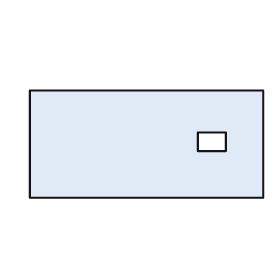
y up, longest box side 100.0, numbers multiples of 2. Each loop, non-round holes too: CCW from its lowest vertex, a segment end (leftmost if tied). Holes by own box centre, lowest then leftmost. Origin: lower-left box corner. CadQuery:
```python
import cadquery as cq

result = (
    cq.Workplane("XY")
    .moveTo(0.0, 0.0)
    .lineTo(100.0, 0.0)
    .lineTo(100.0, 46.0)
    .lineTo(0.0, 46.0)
    .close()
    .moveTo(72.0, 20.0)
    .lineTo(84.0, 20.0)
    .lineTo(84.0, 28.0)
    .lineTo(72.0, 28.0)
    .close()
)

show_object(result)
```